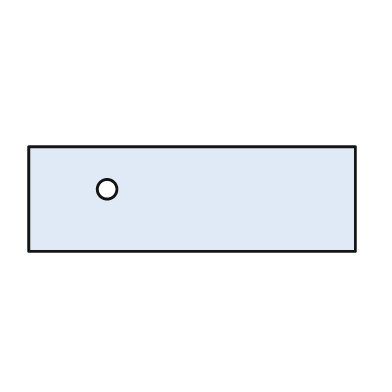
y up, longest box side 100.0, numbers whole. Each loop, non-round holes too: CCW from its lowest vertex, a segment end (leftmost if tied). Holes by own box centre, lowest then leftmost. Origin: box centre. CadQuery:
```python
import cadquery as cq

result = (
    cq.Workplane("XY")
    .moveTo(-50.0, -16.0)
    .lineTo(50.0, -16.0)
    .lineTo(50.0, 16.0)
    .lineTo(-50.0, 16.0)
    .close()
    .moveTo(-26.0, 3.0)
    .circle(3.0)
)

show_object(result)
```